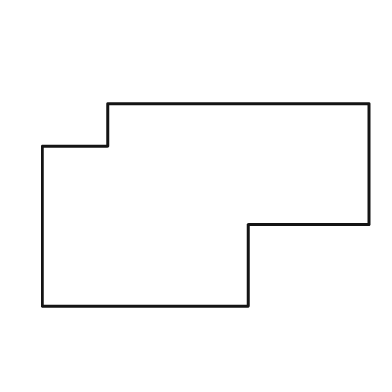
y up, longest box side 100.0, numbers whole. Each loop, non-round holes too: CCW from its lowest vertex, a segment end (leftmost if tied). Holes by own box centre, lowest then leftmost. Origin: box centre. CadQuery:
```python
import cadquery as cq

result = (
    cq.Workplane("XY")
    .moveTo(-50.0, -31.0)
    .lineTo(13.0, -31.0)
    .lineTo(13.0, -6.0)
    .lineTo(50.0, -6.0)
    .lineTo(50.0, 31.0)
    .lineTo(-30.0, 31.0)
    .lineTo(-30.0, 18.0)
    .lineTo(-50.0, 18.0)
    .close()
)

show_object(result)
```